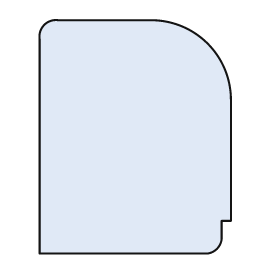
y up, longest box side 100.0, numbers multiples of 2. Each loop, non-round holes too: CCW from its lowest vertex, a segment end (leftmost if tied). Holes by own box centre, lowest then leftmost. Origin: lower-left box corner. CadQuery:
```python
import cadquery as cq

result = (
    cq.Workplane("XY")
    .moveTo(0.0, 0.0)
    .lineTo(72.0, 0.0)
    .threePointArc((76.0, 2.0), (78.0, 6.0))
    .lineTo(78.0, 14.0)
    .lineTo(82.0, 14.0)
    .lineTo(82.0, 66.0)
    .threePointArc((72.0, 90.0), (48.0, 100.0))
    .lineTo(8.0, 100.0)
    .threePointArc((2.0, 98.0), (0.0, 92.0))
    .close()
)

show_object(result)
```